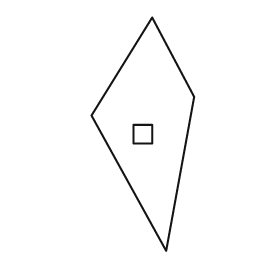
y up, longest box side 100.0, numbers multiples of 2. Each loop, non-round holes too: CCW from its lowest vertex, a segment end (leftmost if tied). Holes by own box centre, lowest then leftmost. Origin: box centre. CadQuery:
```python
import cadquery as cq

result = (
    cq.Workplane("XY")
    .moveTo(10.0, -50.0)
    .lineTo(22.0, 16.0)
    .lineTo(4.0, 50.0)
    .lineTo(-22.0, 8.0)
    .close()
    .moveTo(-4.0, -4.0)
    .lineTo(4.0, -4.0)
    .lineTo(4.0, 4.0)
    .lineTo(-4.0, 4.0)
    .close()
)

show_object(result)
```